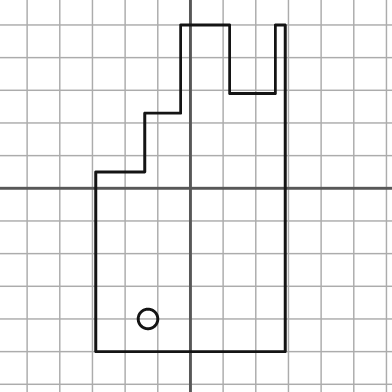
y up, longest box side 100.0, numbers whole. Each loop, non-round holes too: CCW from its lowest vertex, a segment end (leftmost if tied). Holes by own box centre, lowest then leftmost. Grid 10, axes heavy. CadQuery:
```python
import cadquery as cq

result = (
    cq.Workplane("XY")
    .moveTo(-29.0, -50.0)
    .lineTo(29.0, -50.0)
    .lineTo(29.0, 50.0)
    .lineTo(26.0, 50.0)
    .lineTo(26.0, 29.0)
    .lineTo(12.0, 29.0)
    .lineTo(12.0, 50.0)
    .lineTo(-3.0, 50.0)
    .lineTo(-3.0, 23.0)
    .lineTo(-14.0, 23.0)
    .lineTo(-14.0, 5.0)
    .lineTo(-29.0, 5.0)
    .close()
    .moveTo(-13.0, -40.0)
    .circle(3.0)
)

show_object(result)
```